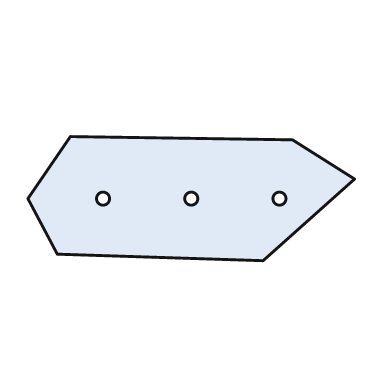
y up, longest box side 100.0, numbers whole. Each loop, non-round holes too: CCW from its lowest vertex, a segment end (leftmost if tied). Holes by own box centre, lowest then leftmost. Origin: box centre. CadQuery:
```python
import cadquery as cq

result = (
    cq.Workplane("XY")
    .moveTo(22.0, -19.0)
    .lineTo(50.0, 6.0)
    .lineTo(31.0, 18.0)
    .lineTo(-37.0, 19.0)
    .lineTo(-50.0, 0.0)
    .lineTo(-41.0, -17.0)
    .close()
    .moveTo(-27.0, 0.0)
    .circle(2.0)
    .moveTo(0.0, 0.0)
    .circle(2.0)
    .moveTo(27.0, 0.0)
    .circle(2.0)
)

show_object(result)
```